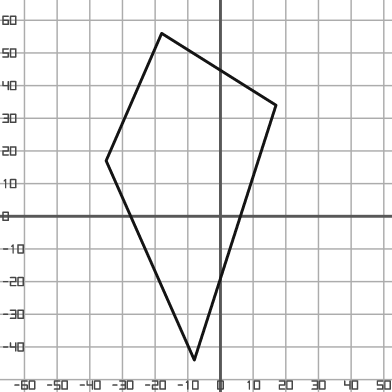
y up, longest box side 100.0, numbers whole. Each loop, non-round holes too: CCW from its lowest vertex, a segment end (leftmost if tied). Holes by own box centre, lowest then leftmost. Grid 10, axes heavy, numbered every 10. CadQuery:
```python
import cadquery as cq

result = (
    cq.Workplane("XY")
    .moveTo(-8.0, -44.0)
    .lineTo(17.0, 34.0)
    .lineTo(-18.0, 56.0)
    .lineTo(-35.0, 17.0)
    .close()
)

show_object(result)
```